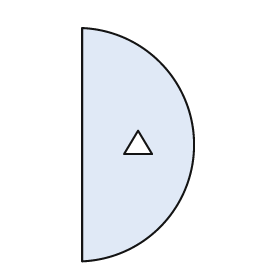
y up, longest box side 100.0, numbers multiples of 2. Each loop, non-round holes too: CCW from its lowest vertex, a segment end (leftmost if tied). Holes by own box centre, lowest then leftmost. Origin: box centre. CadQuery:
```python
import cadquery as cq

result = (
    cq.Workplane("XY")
    .moveTo(-24.0, -50.0)
    .threePointArc((24.0, 0.0), (-24.0, 50.0))
    .close()
    .moveTo(-6.0, -4.0)
    .lineTo(6.0, -4.0)
    .lineTo(0.0, 6.0)
    .close()
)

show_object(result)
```